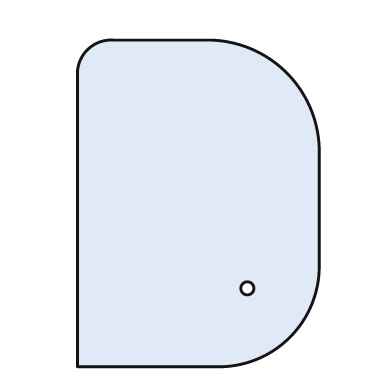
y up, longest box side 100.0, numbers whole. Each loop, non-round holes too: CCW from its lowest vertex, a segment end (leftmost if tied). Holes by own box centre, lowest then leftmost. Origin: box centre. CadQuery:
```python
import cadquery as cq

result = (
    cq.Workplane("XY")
    .moveTo(-37.0, -50.0)
    .lineTo(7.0, -50.0)
    .threePointArc((28.0, -41.0), (37.0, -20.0))
    .lineTo(37.0, 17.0)
    .threePointArc((27.0, 40.0), (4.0, 50.0))
    .lineTo(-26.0, 50.0)
    .threePointArc((-34.0, 47.0), (-37.0, 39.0))
    .close()
    .moveTo(15.0, -26.0)
    .circle(2.0)
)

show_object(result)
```